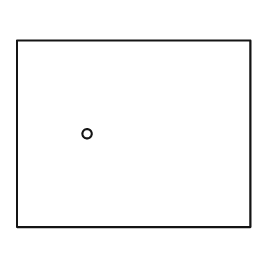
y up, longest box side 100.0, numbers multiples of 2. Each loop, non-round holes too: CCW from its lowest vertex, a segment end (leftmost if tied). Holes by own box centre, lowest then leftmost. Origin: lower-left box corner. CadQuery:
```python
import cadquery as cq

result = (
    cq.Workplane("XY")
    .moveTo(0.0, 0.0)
    .lineTo(100.0, 0.0)
    .lineTo(100.0, 80.0)
    .lineTo(0.0, 80.0)
    .close()
    .moveTo(30.0, 40.0)
    .circle(2.0)
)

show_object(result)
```